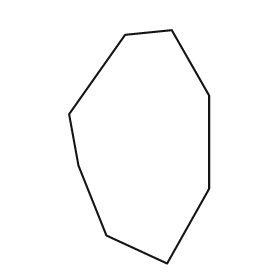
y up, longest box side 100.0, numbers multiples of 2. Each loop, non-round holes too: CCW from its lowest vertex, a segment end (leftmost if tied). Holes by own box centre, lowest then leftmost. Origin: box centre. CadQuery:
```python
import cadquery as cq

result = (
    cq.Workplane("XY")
    .moveTo(12.0, -50.0)
    .lineTo(30.0, -18.0)
    .lineTo(30.0, 22.0)
    .lineTo(14.0, 50.0)
    .lineTo(-6.0, 48.0)
    .lineTo(-30.0, 14.0)
    .lineTo(-26.0, -8.0)
    .lineTo(-14.0, -38.0)
    .close()
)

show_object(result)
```